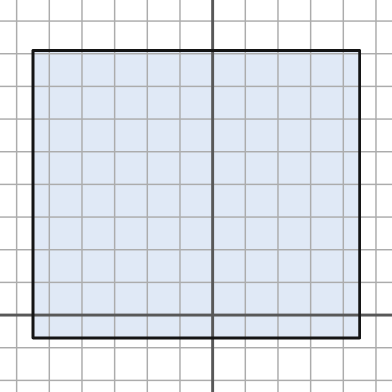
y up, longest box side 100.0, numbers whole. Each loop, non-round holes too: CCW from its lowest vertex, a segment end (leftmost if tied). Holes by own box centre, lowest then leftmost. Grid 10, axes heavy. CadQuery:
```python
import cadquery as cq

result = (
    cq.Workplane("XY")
    .moveTo(-55.0, -7.0)
    .lineTo(45.0, -7.0)
    .lineTo(45.0, 81.0)
    .lineTo(-55.0, 81.0)
    .close()
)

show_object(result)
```